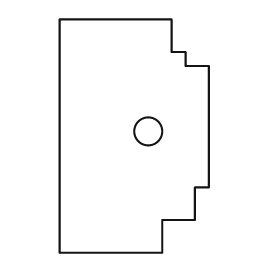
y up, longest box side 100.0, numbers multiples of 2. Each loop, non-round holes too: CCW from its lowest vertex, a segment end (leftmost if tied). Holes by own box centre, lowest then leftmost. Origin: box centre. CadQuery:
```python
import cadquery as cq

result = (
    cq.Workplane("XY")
    .moveTo(-32.0, -50.0)
    .lineTo(12.0, -50.0)
    .lineTo(12.0, -36.0)
    .lineTo(26.0, -36.0)
    .lineTo(26.0, -22.0)
    .lineTo(32.0, -22.0)
    .lineTo(32.0, 30.0)
    .lineTo(22.0, 30.0)
    .lineTo(22.0, 36.0)
    .lineTo(16.0, 36.0)
    .lineTo(16.0, 50.0)
    .lineTo(-32.0, 50.0)
    .close()
    .moveTo(6.0, 2.0)
    .circle(6.0)
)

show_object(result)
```